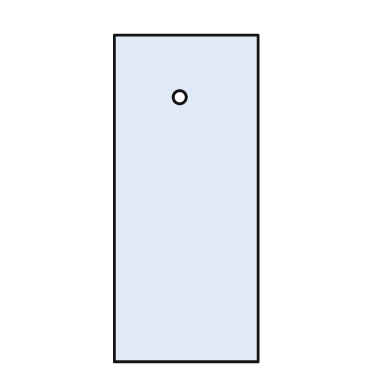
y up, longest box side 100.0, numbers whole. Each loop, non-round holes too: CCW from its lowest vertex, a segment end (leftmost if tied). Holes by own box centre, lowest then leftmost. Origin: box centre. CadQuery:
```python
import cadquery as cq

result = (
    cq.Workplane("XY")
    .moveTo(-22.0, -50.0)
    .lineTo(22.0, -50.0)
    .lineTo(22.0, 50.0)
    .lineTo(-22.0, 50.0)
    .close()
    .moveTo(-2.0, 31.0)
    .circle(2.0)
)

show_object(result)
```